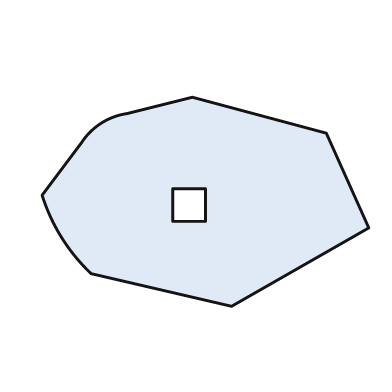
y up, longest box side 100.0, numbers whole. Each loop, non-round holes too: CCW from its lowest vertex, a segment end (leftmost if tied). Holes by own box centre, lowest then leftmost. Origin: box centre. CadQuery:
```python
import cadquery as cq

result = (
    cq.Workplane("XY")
    .moveTo(8.0, -32.0)
    .lineTo(50.0, -8.0)
    .lineTo(37.0, 21.0)
    .lineTo(-4.0, 32.0)
    .lineTo(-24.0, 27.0)
    .threePointArc((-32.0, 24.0), (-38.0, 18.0))
    .lineTo(-50.0, 2.0)
    .threePointArc((-44.0, -11.0), (-35.0, -22.0))
    .close()
    .moveTo(-10.0, -6.0)
    .lineTo(0.0, -6.0)
    .lineTo(0.0, 4.0)
    .lineTo(-10.0, 4.0)
    .close()
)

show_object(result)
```